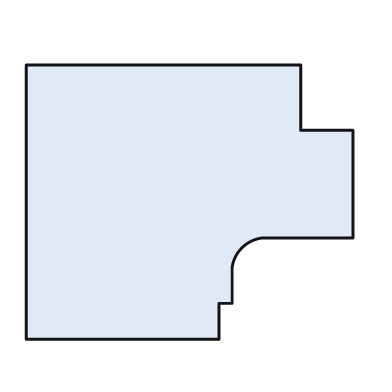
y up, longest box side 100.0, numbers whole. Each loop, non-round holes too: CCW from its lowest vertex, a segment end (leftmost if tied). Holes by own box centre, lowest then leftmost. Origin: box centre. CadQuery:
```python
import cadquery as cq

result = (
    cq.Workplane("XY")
    .moveTo(-50.0, -42.0)
    .lineTo(9.0, -42.0)
    .lineTo(9.0, -31.0)
    .lineTo(13.0, -31.0)
    .lineTo(13.0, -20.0)
    .threePointArc((16.0, -14.0), (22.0, -11.0))
    .lineTo(50.0, -11.0)
    .lineTo(50.0, 22.0)
    .lineTo(34.0, 22.0)
    .lineTo(34.0, 42.0)
    .lineTo(-50.0, 42.0)
    .close()
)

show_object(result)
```